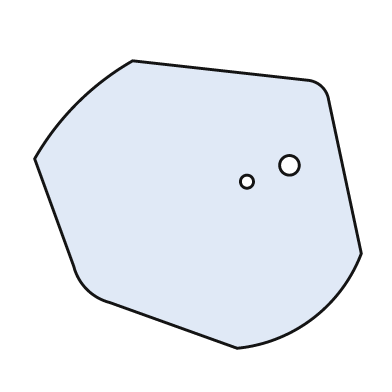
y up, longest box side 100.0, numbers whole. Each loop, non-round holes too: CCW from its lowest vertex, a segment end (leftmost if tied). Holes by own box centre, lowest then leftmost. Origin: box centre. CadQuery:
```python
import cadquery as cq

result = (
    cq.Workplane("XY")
    .moveTo(12.0, -44.0)
    .threePointArc((35.0, -35.0), (50.0, -15.0))
    .lineTo(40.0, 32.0)
    .threePointArc((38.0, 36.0), (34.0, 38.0))
    .lineTo(-20.0, 44.0)
    .threePointArc((-37.0, 31.0), (-50.0, 14.0))
    .lineTo(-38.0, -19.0)
    .threePointArc((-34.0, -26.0), (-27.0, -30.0))
    .close()
    .moveTo(15.0, 7.0)
    .circle(2.0)
    .moveTo(28.0, 12.0)
    .circle(3.0)
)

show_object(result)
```